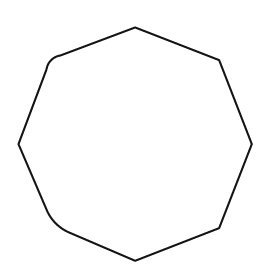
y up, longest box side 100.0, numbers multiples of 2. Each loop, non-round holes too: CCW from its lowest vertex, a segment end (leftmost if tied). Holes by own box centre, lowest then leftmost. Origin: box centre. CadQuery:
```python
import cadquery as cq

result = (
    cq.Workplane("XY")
    .moveTo(0.0, -50.0)
    .lineTo(36.0, -36.0)
    .lineTo(50.0, 0.0)
    .lineTo(36.0, 36.0)
    .lineTo(0.0, 50.0)
    .lineTo(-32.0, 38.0)
    .threePointArc((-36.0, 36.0), (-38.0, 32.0))
    .lineTo(-50.0, 0.0)
    .lineTo(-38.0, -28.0)
    .threePointArc((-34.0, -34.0), (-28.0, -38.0))
    .close()
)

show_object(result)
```